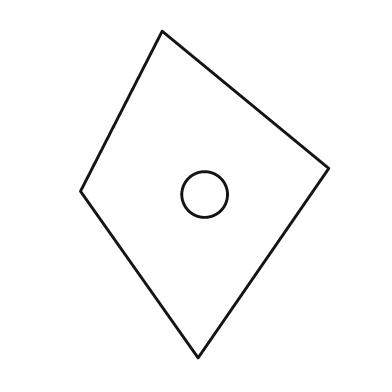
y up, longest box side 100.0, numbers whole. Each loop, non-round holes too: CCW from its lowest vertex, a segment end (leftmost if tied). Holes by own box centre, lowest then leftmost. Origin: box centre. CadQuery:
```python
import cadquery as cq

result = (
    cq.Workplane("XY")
    .moveTo(-2.0, -50.0)
    .lineTo(38.0, 8.0)
    .lineTo(-13.0, 50.0)
    .lineTo(-38.0, 1.0)
    .close()
    .moveTo(0.0, 0.0)
    .circle(7.0)
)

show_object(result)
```